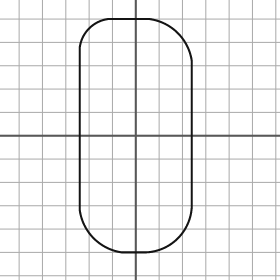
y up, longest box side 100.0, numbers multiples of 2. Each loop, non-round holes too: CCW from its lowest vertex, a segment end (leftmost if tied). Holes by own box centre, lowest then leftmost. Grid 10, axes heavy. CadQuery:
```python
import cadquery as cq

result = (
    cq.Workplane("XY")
    .moveTo(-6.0, -50.0)
    .lineTo(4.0, -50.0)
    .threePointArc((18.0, -44.0), (24.0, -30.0))
    .lineTo(24.0, 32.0)
    .threePointArc((18.0, 44.0), (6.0, 50.0))
    .lineTo(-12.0, 50.0)
    .threePointArc((-20.0, 46.0), (-24.0, 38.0))
    .lineTo(-24.0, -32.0)
    .threePointArc((-18.0, -44.0), (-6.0, -50.0))
    .close()
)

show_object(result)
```